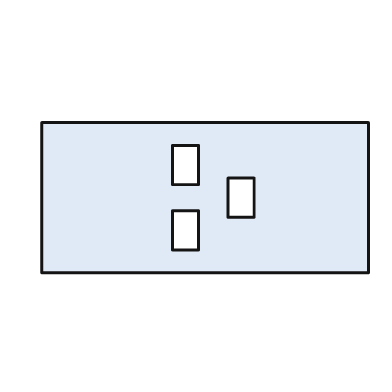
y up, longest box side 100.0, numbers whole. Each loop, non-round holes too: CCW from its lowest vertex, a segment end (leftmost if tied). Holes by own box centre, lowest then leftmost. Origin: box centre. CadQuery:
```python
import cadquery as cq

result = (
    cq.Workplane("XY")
    .moveTo(-50.0, -23.0)
    .lineTo(50.0, -23.0)
    .lineTo(50.0, 23.0)
    .lineTo(-50.0, 23.0)
    .close()
    .moveTo(-10.0, -16.0)
    .lineTo(-2.0, -16.0)
    .lineTo(-2.0, -4.0)
    .lineTo(-10.0, -4.0)
    .close()
    .moveTo(7.0, -6.0)
    .lineTo(15.0, -6.0)
    .lineTo(15.0, 6.0)
    .lineTo(7.0, 6.0)
    .close()
    .moveTo(-10.0, 4.0)
    .lineTo(-2.0, 4.0)
    .lineTo(-2.0, 16.0)
    .lineTo(-10.0, 16.0)
    .close()
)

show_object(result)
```